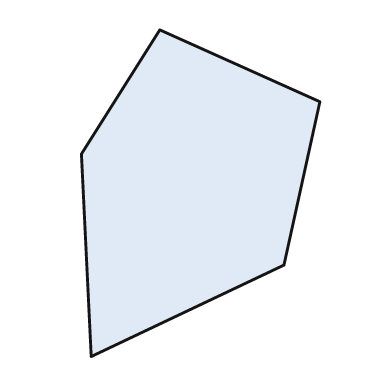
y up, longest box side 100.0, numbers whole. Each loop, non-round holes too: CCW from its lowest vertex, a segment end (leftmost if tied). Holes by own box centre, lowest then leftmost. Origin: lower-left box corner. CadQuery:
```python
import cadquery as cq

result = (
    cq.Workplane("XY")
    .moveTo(3.0, 0.0)
    .lineTo(62.0, 28.0)
    .lineTo(73.0, 78.0)
    .lineTo(24.0, 100.0)
    .lineTo(0.0, 62.0)
    .close()
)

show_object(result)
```